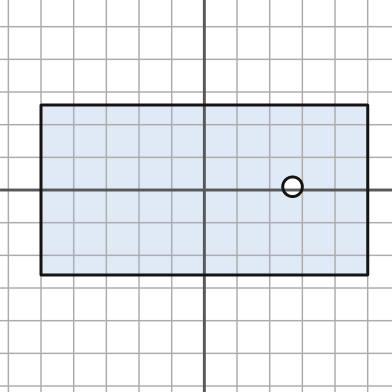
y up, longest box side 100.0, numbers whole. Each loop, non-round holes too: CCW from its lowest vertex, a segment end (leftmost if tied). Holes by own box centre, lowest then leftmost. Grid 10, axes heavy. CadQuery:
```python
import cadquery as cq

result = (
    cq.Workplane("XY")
    .moveTo(-50.0, -26.0)
    .lineTo(50.0, -26.0)
    .lineTo(50.0, 26.0)
    .lineTo(-50.0, 26.0)
    .close()
    .moveTo(27.0, 1.0)
    .circle(3.0)
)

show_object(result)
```